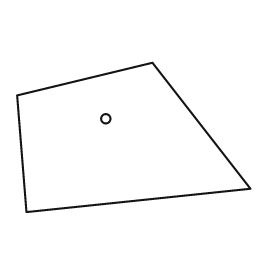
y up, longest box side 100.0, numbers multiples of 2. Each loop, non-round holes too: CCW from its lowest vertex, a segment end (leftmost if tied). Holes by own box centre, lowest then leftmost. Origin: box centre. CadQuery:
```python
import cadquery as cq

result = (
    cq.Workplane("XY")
    .moveTo(-46.0, -32.0)
    .lineTo(50.0, -22.0)
    .lineTo(8.0, 32.0)
    .lineTo(-50.0, 18.0)
    .close()
    .moveTo(-12.0, 8.0)
    .circle(2.0)
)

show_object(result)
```